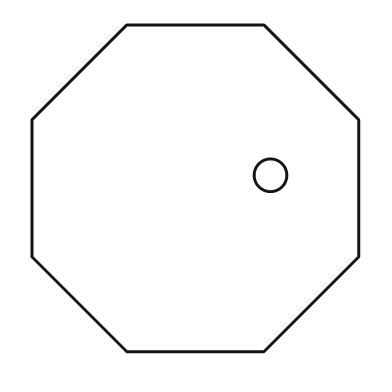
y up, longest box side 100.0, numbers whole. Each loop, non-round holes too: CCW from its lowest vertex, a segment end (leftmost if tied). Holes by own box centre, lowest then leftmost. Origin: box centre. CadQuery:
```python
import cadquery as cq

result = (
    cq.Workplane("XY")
    .moveTo(-21.0, -50.0)
    .lineTo(21.0, -50.0)
    .lineTo(50.0, -21.0)
    .lineTo(50.0, 21.0)
    .lineTo(21.0, 50.0)
    .lineTo(-21.0, 50.0)
    .lineTo(-50.0, 21.0)
    .lineTo(-50.0, -21.0)
    .close()
    .moveTo(23.0, 4.0)
    .circle(5.0)
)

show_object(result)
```